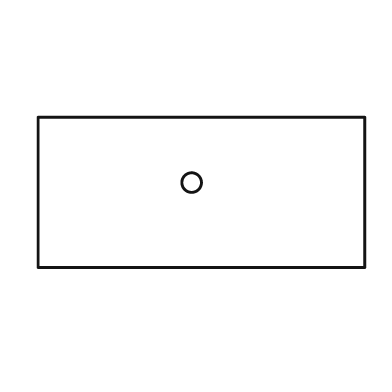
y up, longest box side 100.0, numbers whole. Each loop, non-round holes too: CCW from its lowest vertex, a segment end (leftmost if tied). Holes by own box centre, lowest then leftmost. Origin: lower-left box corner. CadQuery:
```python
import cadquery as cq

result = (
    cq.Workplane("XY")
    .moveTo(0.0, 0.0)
    .lineTo(100.0, 0.0)
    .lineTo(100.0, 46.0)
    .lineTo(0.0, 46.0)
    .close()
    .moveTo(47.0, 26.0)
    .circle(3.0)
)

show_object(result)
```